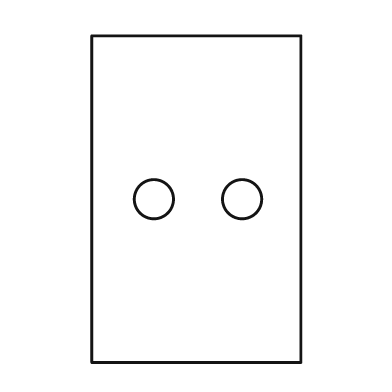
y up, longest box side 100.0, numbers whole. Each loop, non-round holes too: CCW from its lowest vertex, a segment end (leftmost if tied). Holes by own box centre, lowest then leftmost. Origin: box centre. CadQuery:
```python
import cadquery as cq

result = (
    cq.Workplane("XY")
    .moveTo(-32.0, -50.0)
    .lineTo(32.0, -50.0)
    .lineTo(32.0, 50.0)
    .lineTo(-32.0, 50.0)
    .close()
    .moveTo(-13.0, 0.0)
    .circle(6.0)
    .moveTo(14.0, 0.0)
    .circle(6.0)
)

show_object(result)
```